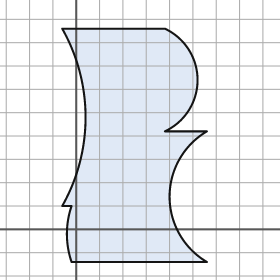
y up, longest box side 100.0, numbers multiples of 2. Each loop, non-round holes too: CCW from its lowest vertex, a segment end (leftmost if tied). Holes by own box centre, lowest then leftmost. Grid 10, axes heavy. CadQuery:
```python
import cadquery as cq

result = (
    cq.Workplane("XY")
    .moveTo(-2.0, -14.0)
    .lineTo(56.0, -14.0)
    .threePointArc((40.0, 14.0), (56.0, 42.0))
    .lineTo(38.0, 42.0)
    .threePointArc((52.0, 64.0), (38.0, 86.0))
    .lineTo(-6.0, 86.0)
    .threePointArc((4.0, 48.0), (-6.0, 10.0))
    .lineTo(-2.0, 10.0)
    .threePointArc((-4.0, -2.0), (-2.0, -14.0))
    .close()
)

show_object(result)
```